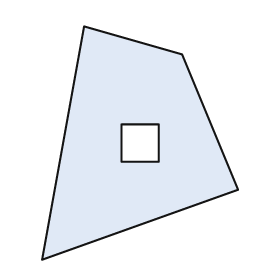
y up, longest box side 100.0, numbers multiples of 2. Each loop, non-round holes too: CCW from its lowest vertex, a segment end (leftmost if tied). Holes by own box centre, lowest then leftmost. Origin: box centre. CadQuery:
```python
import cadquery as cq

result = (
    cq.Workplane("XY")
    .moveTo(-42.0, -50.0)
    .lineTo(42.0, -20.0)
    .lineTo(18.0, 38.0)
    .lineTo(-24.0, 50.0)
    .close()
    .moveTo(-8.0, -8.0)
    .lineTo(8.0, -8.0)
    .lineTo(8.0, 8.0)
    .lineTo(-8.0, 8.0)
    .close()
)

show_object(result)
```